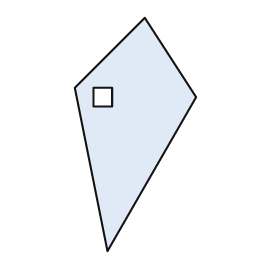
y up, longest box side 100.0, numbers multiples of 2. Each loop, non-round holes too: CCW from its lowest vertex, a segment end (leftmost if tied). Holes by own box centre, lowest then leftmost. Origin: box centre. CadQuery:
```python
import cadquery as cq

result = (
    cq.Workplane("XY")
    .moveTo(-12.0, -50.0)
    .lineTo(26.0, 16.0)
    .lineTo(4.0, 50.0)
    .lineTo(-26.0, 20.0)
    .close()
    .moveTo(-18.0, 12.0)
    .lineTo(-10.0, 12.0)
    .lineTo(-10.0, 20.0)
    .lineTo(-18.0, 20.0)
    .close()
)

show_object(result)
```